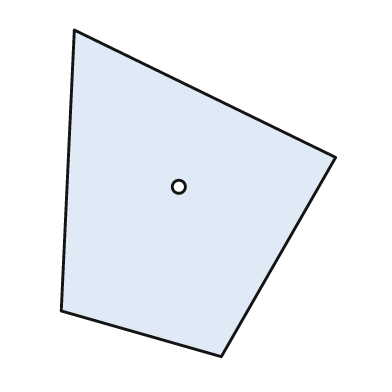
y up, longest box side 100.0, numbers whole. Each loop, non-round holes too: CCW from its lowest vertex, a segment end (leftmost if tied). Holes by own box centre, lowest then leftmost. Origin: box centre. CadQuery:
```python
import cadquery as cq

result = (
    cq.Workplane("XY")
    .moveTo(7.0, -50.0)
    .lineTo(42.0, 11.0)
    .lineTo(-38.0, 50.0)
    .lineTo(-42.0, -36.0)
    .close()
    .moveTo(-6.0, 2.0)
    .circle(2.0)
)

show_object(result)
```